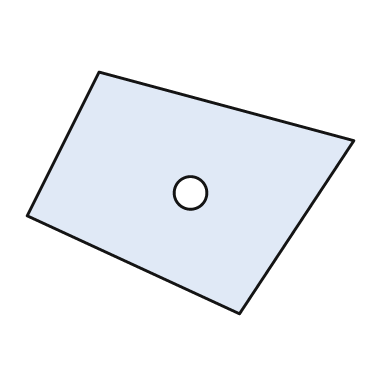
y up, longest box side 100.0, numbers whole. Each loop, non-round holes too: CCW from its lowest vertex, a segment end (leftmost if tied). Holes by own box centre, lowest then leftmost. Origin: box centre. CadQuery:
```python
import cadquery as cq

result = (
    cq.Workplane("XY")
    .moveTo(15.0, -37.0)
    .lineTo(50.0, 16.0)
    .lineTo(-28.0, 37.0)
    .lineTo(-50.0, -7.0)
    .close()
    .moveTo(0.0, 0.0)
    .circle(5.0)
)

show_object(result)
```